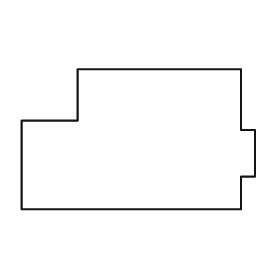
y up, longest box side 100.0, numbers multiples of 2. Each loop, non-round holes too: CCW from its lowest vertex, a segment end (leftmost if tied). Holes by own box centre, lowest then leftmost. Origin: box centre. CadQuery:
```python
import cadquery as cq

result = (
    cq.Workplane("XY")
    .moveTo(-50.0, -30.0)
    .lineTo(44.0, -30.0)
    .lineTo(44.0, -16.0)
    .lineTo(50.0, -16.0)
    .lineTo(50.0, 4.0)
    .lineTo(44.0, 4.0)
    .lineTo(44.0, 30.0)
    .lineTo(-26.0, 30.0)
    .lineTo(-26.0, 8.0)
    .lineTo(-50.0, 8.0)
    .close()
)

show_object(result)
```